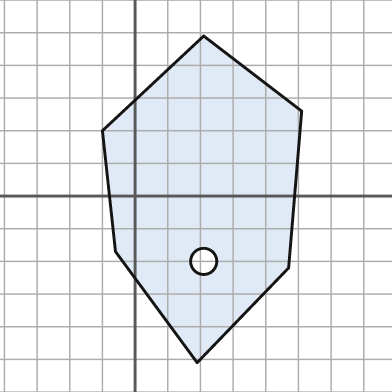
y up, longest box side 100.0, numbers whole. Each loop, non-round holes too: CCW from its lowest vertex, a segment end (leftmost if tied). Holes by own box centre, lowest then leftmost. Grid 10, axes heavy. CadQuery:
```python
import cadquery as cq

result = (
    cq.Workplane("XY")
    .moveTo(19.0, -51.0)
    .lineTo(47.0, -22.0)
    .lineTo(51.0, 26.0)
    .lineTo(21.0, 49.0)
    .lineTo(-10.0, 20.0)
    .lineTo(-6.0, -17.0)
    .close()
    .moveTo(21.0, -20.0)
    .circle(4.0)
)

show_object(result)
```